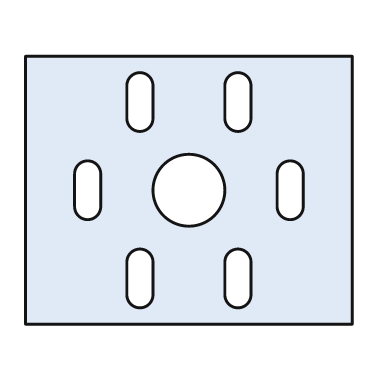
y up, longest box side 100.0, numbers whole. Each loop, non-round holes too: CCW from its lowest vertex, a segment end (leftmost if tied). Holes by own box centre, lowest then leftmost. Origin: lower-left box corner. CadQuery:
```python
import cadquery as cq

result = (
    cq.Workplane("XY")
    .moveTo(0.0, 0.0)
    .lineTo(100.0, 0.0)
    .lineTo(100.0, 82.0)
    .lineTo(0.0, 82.0)
    .close()
    .moveTo(31.0, 9.0)
    .threePointArc((35.0, 5.0), (39.0, 9.0))
    .lineTo(39.0, 19.0)
    .threePointArc((35.0, 23.0), (31.0, 19.0))
    .close()
    .moveTo(61.0, 9.0)
    .threePointArc((65.0, 5.0), (69.0, 9.0))
    .lineTo(69.0, 19.0)
    .threePointArc((65.0, 23.0), (61.0, 19.0))
    .close()
    .moveTo(15.0, 36.0)
    .threePointArc((19.0, 32.0), (23.0, 36.0))
    .lineTo(23.0, 46.0)
    .threePointArc((19.0, 50.0), (15.0, 46.0))
    .close()
    .moveTo(50.0, 41.0)
    .circle(11.0)
    .moveTo(77.0, 36.0)
    .threePointArc((81.0, 32.0), (85.0, 36.0))
    .lineTo(85.0, 46.0)
    .threePointArc((81.0, 50.0), (77.0, 46.0))
    .close()
    .moveTo(31.0, 63.0)
    .threePointArc((35.0, 59.0), (39.0, 63.0))
    .lineTo(39.0, 73.0)
    .threePointArc((35.0, 77.0), (31.0, 73.0))
    .close()
    .moveTo(61.0, 63.0)
    .threePointArc((65.0, 59.0), (69.0, 63.0))
    .lineTo(69.0, 73.0)
    .threePointArc((65.0, 77.0), (61.0, 73.0))
    .close()
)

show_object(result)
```